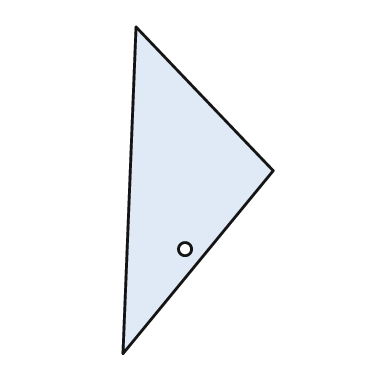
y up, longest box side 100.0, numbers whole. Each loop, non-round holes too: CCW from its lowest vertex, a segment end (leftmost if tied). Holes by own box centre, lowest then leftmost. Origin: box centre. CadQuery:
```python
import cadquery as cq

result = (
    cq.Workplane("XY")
    .moveTo(-23.0, -50.0)
    .lineTo(23.0, 6.0)
    .lineTo(-19.0, 50.0)
    .close()
    .moveTo(-4.0, -18.0)
    .circle(2.0)
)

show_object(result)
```